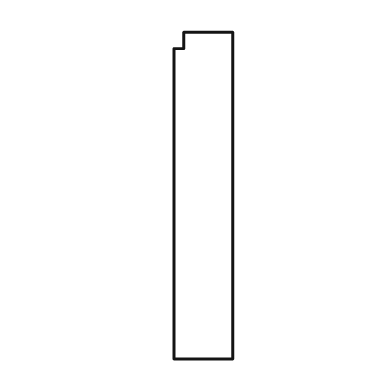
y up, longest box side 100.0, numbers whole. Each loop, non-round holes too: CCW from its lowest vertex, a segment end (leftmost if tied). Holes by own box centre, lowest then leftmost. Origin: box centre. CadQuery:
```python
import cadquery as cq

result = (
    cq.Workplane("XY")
    .moveTo(-9.0, -50.0)
    .lineTo(9.0, -50.0)
    .lineTo(9.0, 50.0)
    .lineTo(-6.0, 50.0)
    .lineTo(-6.0, 45.0)
    .lineTo(-9.0, 45.0)
    .close()
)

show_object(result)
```